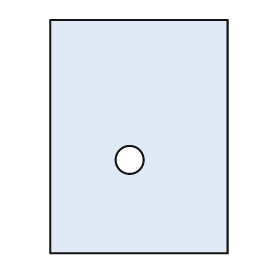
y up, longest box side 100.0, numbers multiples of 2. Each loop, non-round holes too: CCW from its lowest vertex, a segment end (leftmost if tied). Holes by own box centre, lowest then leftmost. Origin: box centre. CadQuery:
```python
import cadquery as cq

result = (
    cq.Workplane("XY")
    .moveTo(-38.0, -50.0)
    .lineTo(38.0, -50.0)
    .lineTo(38.0, 50.0)
    .lineTo(-38.0, 50.0)
    .close()
    .moveTo(-4.0, -10.0)
    .circle(6.0)
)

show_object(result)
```